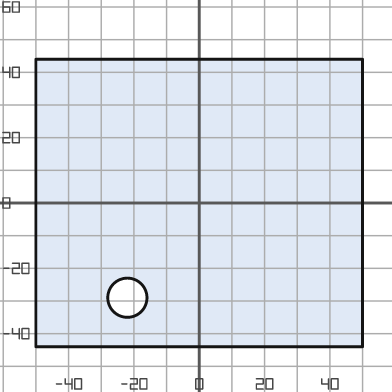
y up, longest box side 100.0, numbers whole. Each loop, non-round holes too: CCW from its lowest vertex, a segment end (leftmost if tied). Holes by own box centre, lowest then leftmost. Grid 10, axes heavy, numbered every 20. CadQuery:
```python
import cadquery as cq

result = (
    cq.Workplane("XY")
    .moveTo(-50.0, -44.0)
    .lineTo(50.0, -44.0)
    .lineTo(50.0, 44.0)
    .lineTo(-50.0, 44.0)
    .close()
    .moveTo(-22.0, -29.0)
    .circle(6.0)
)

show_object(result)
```